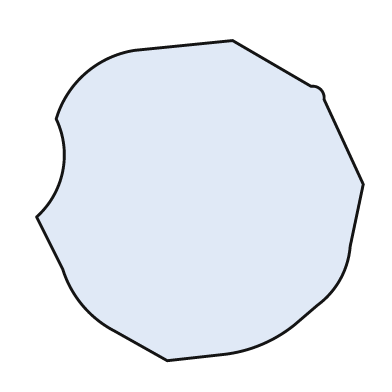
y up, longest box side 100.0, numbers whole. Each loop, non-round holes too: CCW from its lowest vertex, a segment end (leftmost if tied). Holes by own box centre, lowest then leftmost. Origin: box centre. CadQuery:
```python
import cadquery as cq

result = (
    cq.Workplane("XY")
    .moveTo(-10.0, -49.0)
    .lineTo(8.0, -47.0)
    .threePointArc((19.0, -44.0), (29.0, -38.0))
    .lineTo(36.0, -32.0)
    .threePointArc((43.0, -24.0), (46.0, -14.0))
    .lineTo(50.0, 5.0)
    .lineTo(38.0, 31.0)
    .threePointArc((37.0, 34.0), (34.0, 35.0))
    .lineTo(10.0, 49.0)
    .lineTo(-20.0, 46.0)
    .threePointArc((-35.0, 39.0), (-44.0, 25.0))
    .threePointArc((-42.0, 9.0), (-50.0, -5.0))
    .lineTo(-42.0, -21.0)
    .threePointArc((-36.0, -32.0), (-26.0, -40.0))
    .close()
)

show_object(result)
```